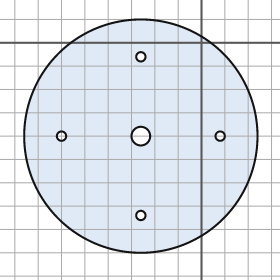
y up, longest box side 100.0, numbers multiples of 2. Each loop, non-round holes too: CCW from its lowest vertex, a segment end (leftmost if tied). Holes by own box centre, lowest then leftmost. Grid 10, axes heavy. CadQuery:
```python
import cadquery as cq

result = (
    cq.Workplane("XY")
    .moveTo(-26.0, -40.0)
    .circle(50.0)
    .moveTo(-26.0, -74.0)
    .circle(2.0)
    .moveTo(-60.0, -40.0)
    .circle(2.0)
    .moveTo(-26.0, -40.0)
    .circle(4.0)
    .moveTo(8.0, -40.0)
    .circle(2.0)
    .moveTo(-26.0, -6.0)
    .circle(2.0)
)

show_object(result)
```